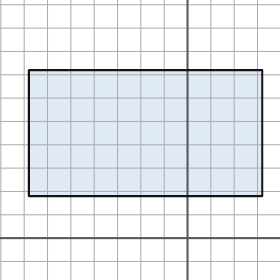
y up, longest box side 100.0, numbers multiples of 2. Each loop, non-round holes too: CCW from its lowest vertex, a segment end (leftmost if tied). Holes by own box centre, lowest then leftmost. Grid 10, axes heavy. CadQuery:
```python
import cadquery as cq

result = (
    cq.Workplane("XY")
    .moveTo(-68.0, 18.0)
    .lineTo(32.0, 18.0)
    .lineTo(32.0, 72.0)
    .lineTo(-68.0, 72.0)
    .close()
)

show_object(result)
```